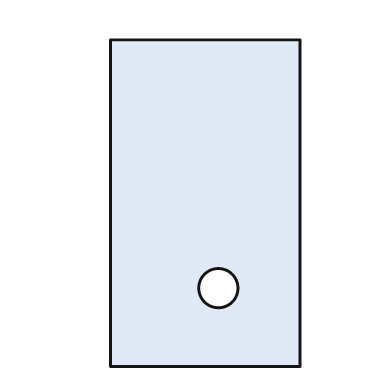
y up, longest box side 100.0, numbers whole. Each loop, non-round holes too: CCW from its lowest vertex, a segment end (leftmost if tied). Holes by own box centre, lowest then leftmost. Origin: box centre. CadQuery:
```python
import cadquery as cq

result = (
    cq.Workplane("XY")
    .moveTo(-29.0, -50.0)
    .lineTo(29.0, -50.0)
    .lineTo(29.0, 50.0)
    .lineTo(-29.0, 50.0)
    .close()
    .moveTo(4.0, -26.0)
    .circle(6.0)
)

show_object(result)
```